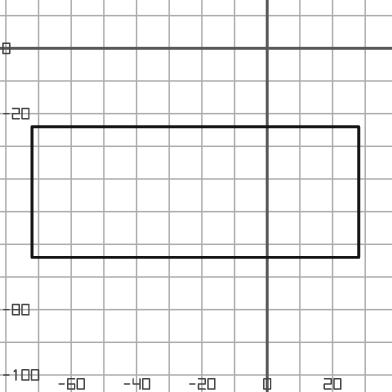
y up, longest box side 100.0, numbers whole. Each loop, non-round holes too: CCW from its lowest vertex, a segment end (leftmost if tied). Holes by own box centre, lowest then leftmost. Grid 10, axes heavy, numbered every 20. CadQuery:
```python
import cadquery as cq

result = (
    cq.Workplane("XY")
    .moveTo(-72.0, -64.0)
    .lineTo(28.0, -64.0)
    .lineTo(28.0, -24.0)
    .lineTo(-72.0, -24.0)
    .close()
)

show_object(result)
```